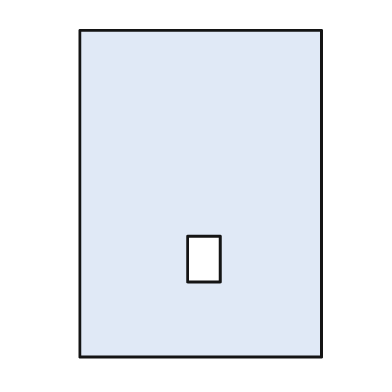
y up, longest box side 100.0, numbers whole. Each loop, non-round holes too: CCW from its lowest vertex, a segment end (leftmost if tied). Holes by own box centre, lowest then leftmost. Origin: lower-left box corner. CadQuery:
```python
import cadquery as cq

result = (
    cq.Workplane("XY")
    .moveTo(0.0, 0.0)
    .lineTo(74.0, 0.0)
    .lineTo(74.0, 100.0)
    .lineTo(0.0, 100.0)
    .close()
    .moveTo(33.0, 23.0)
    .lineTo(43.0, 23.0)
    .lineTo(43.0, 37.0)
    .lineTo(33.0, 37.0)
    .close()
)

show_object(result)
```